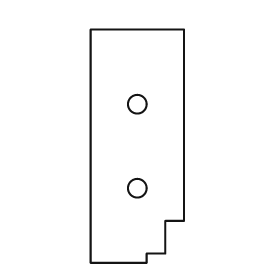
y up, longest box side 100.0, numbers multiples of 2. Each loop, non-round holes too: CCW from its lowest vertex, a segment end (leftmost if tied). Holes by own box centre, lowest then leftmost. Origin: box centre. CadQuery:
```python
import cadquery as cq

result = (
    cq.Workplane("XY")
    .moveTo(-20.0, -50.0)
    .lineTo(4.0, -50.0)
    .lineTo(4.0, -46.0)
    .lineTo(12.0, -46.0)
    .lineTo(12.0, -32.0)
    .lineTo(20.0, -32.0)
    .lineTo(20.0, 50.0)
    .lineTo(-20.0, 50.0)
    .close()
    .moveTo(0.0, -18.0)
    .circle(4.0)
    .moveTo(0.0, 18.0)
    .circle(4.0)
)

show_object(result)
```